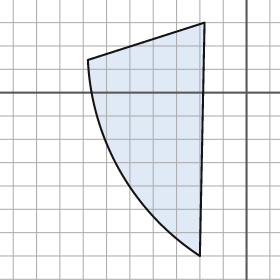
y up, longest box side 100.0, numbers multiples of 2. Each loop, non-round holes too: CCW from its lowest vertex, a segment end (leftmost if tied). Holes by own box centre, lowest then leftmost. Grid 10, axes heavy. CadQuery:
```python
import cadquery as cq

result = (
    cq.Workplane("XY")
    .moveTo(-20.0, -70.0)
    .lineTo(-18.0, 30.0)
    .lineTo(-68.0, 14.0)
    .threePointArc((-54.0, -34.0), (-20.0, -70.0))
    .close()
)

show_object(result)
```